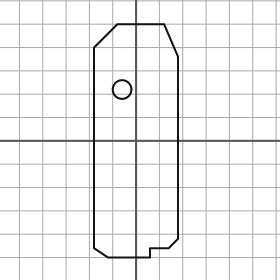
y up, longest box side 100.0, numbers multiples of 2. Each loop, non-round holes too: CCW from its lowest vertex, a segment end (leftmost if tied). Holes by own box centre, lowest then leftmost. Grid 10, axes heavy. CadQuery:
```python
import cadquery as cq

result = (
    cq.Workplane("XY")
    .moveTo(-12.0, -50.0)
    .lineTo(6.0, -50.0)
    .lineTo(6.0, -46.0)
    .lineTo(14.0, -46.0)
    .lineTo(18.0, -42.0)
    .lineTo(18.0, 36.0)
    .lineTo(12.0, 50.0)
    .lineTo(-8.0, 50.0)
    .lineTo(-18.0, 40.0)
    .lineTo(-18.0, -46.0)
    .close()
    .moveTo(-6.0, 22.0)
    .circle(4.0)
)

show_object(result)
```